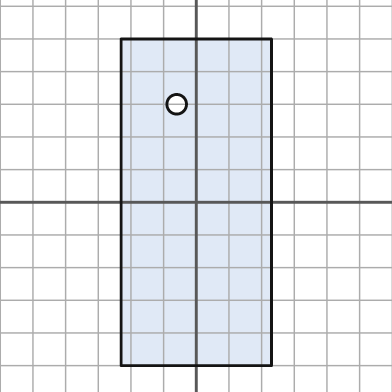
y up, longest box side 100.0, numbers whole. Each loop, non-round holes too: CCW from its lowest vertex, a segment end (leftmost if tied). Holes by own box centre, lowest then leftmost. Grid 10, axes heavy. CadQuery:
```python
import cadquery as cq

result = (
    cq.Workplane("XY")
    .moveTo(-23.0, -50.0)
    .lineTo(23.0, -50.0)
    .lineTo(23.0, 50.0)
    .lineTo(-23.0, 50.0)
    .close()
    .moveTo(-6.0, 30.0)
    .circle(3.0)
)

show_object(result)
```